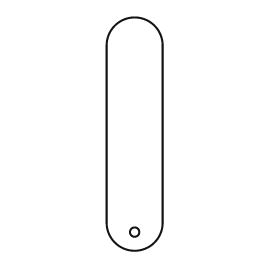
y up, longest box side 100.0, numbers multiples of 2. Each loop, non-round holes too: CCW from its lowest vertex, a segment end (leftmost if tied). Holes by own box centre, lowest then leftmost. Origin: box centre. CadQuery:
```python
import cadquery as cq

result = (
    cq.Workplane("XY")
    .moveTo(-12.0, -38.0)
    .threePointArc((0.0, -50.0), (12.0, -38.0))
    .lineTo(12.0, 38.0)
    .threePointArc((0.0, 50.0), (-12.0, 38.0))
    .close()
    .moveTo(0.0, -42.0)
    .circle(2.0)
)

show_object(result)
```